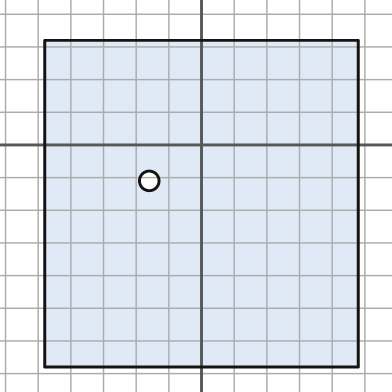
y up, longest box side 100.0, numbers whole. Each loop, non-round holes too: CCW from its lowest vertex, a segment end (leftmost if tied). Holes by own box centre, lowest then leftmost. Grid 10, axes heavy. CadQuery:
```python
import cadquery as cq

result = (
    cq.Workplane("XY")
    .moveTo(-48.0, -68.0)
    .lineTo(48.0, -68.0)
    .lineTo(48.0, 32.0)
    .lineTo(-48.0, 32.0)
    .close()
    .moveTo(-16.0, -11.0)
    .circle(3.0)
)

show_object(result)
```